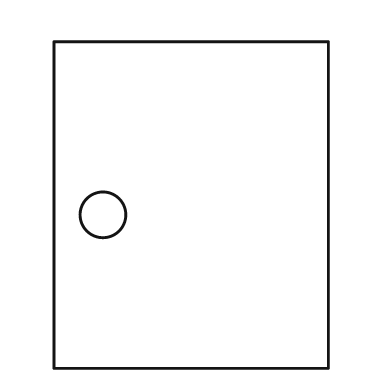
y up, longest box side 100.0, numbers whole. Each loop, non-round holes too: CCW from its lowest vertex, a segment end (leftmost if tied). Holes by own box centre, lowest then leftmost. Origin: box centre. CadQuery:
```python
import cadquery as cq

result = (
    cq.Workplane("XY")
    .moveTo(-42.0, -50.0)
    .lineTo(42.0, -50.0)
    .lineTo(42.0, 50.0)
    .lineTo(-42.0, 50.0)
    .close()
    .moveTo(-27.0, -3.0)
    .circle(7.0)
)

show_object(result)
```